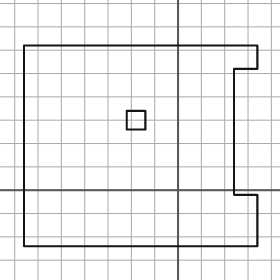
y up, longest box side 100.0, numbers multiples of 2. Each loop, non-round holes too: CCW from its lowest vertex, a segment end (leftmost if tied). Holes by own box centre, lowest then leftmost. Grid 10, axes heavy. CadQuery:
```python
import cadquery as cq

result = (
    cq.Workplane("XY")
    .moveTo(-66.0, -24.0)
    .lineTo(34.0, -24.0)
    .lineTo(34.0, -2.0)
    .lineTo(24.0, -2.0)
    .lineTo(24.0, 52.0)
    .lineTo(34.0, 52.0)
    .lineTo(34.0, 62.0)
    .lineTo(-66.0, 62.0)
    .close()
    .moveTo(-22.0, 26.0)
    .lineTo(-14.0, 26.0)
    .lineTo(-14.0, 34.0)
    .lineTo(-22.0, 34.0)
    .close()
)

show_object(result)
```